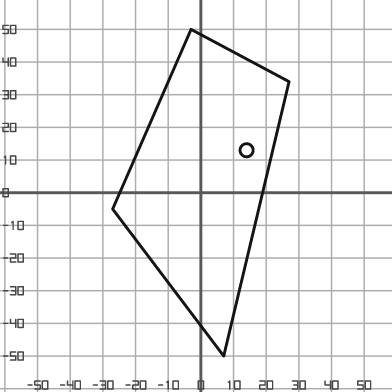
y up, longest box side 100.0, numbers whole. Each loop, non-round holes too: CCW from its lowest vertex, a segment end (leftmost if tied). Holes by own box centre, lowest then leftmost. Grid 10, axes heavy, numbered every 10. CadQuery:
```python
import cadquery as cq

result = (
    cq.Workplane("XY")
    .moveTo(7.0, -50.0)
    .lineTo(27.0, 34.0)
    .lineTo(-3.0, 50.0)
    .lineTo(-27.0, -5.0)
    .close()
    .moveTo(14.0, 13.0)
    .circle(2.0)
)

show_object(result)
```